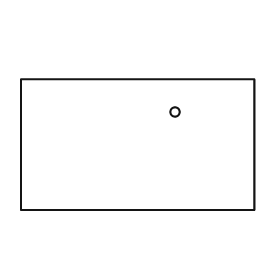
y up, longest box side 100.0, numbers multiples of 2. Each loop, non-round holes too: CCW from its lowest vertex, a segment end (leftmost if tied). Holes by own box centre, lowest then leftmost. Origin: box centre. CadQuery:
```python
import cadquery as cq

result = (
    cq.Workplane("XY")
    .moveTo(-50.0, -28.0)
    .lineTo(50.0, -28.0)
    .lineTo(50.0, 28.0)
    .lineTo(-50.0, 28.0)
    .close()
    .moveTo(16.0, 14.0)
    .circle(2.0)
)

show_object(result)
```